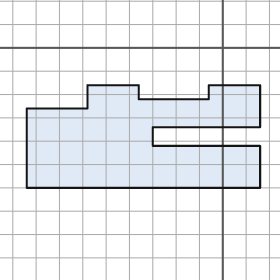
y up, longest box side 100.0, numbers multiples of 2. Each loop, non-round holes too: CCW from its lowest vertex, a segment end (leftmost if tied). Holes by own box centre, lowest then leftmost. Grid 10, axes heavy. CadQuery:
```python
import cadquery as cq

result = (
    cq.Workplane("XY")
    .moveTo(-84.0, -60.0)
    .lineTo(16.0, -60.0)
    .lineTo(16.0, -42.0)
    .lineTo(-30.0, -42.0)
    .lineTo(-30.0, -34.0)
    .lineTo(16.0, -34.0)
    .lineTo(16.0, -16.0)
    .lineTo(-6.0, -16.0)
    .lineTo(-6.0, -22.0)
    .lineTo(-36.0, -22.0)
    .lineTo(-36.0, -16.0)
    .lineTo(-58.0, -16.0)
    .lineTo(-58.0, -26.0)
    .lineTo(-84.0, -26.0)
    .close()
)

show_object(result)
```